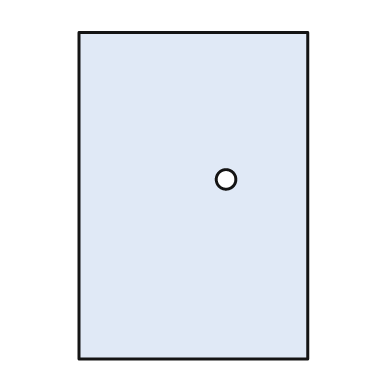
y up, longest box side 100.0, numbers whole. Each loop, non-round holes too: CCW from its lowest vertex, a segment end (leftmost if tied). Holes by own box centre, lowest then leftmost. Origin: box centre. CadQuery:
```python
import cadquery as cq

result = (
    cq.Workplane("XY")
    .moveTo(-35.0, -50.0)
    .lineTo(35.0, -50.0)
    .lineTo(35.0, 50.0)
    .lineTo(-35.0, 50.0)
    .close()
    .moveTo(10.0, 5.0)
    .circle(3.0)
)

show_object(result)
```